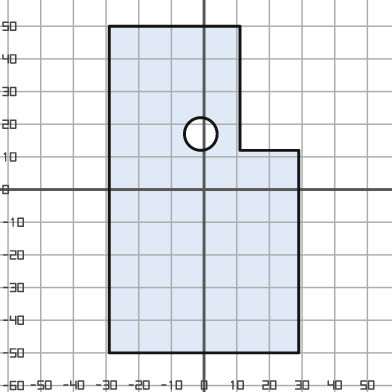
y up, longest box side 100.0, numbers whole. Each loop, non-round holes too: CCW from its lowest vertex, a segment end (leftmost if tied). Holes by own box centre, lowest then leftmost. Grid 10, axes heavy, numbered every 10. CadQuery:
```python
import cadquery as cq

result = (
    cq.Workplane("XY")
    .moveTo(-29.0, -50.0)
    .lineTo(29.0, -50.0)
    .lineTo(29.0, 12.0)
    .lineTo(11.0, 12.0)
    .lineTo(11.0, 50.0)
    .lineTo(-29.0, 50.0)
    .close()
    .moveTo(-1.0, 17.0)
    .circle(5.0)
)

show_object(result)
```